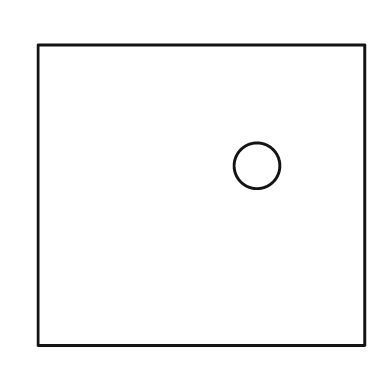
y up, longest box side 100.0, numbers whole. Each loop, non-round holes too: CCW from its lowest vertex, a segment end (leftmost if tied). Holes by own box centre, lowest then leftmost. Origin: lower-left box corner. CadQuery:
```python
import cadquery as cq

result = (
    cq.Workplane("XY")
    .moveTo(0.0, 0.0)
    .lineTo(100.0, 0.0)
    .lineTo(100.0, 92.0)
    .lineTo(0.0, 92.0)
    .close()
    .moveTo(67.0, 55.0)
    .circle(7.0)
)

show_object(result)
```